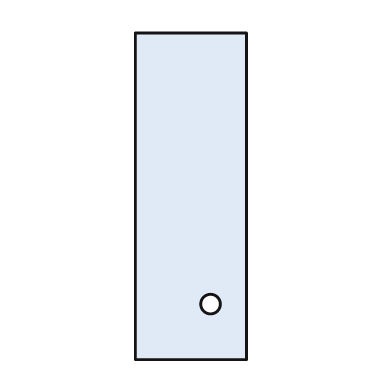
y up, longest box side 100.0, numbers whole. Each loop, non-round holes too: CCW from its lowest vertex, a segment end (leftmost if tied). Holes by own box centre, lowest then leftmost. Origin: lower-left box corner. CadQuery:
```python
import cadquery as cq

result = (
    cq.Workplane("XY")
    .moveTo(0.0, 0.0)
    .lineTo(34.0, 0.0)
    .lineTo(34.0, 100.0)
    .lineTo(0.0, 100.0)
    .close()
    .moveTo(23.0, 17.0)
    .circle(3.0)
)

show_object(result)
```